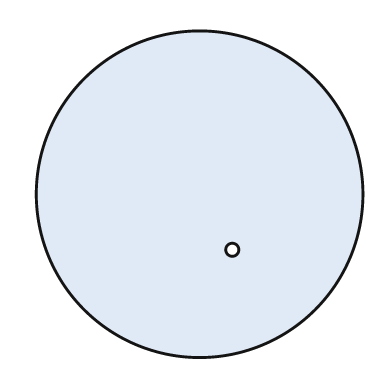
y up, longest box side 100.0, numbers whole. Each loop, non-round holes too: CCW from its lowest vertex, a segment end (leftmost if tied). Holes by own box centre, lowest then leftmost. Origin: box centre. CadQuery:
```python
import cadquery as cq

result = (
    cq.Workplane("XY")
    .moveTo(0.0, 0.0)
    .circle(50.0)
    .moveTo(10.0, -17.0)
    .circle(2.0)
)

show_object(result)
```